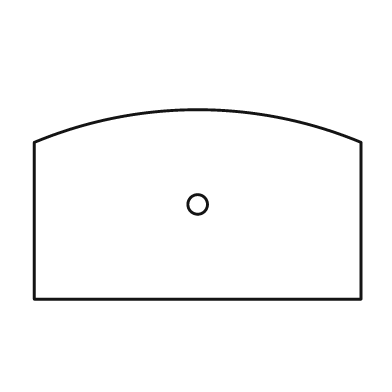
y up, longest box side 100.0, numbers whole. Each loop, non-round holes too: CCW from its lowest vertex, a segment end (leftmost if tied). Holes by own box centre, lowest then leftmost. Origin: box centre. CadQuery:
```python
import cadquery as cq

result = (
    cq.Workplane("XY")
    .moveTo(-50.0, -29.0)
    .lineTo(50.0, -29.0)
    .lineTo(50.0, 19.0)
    .threePointArc((0.0, 29.0), (-50.0, 19.0))
    .close()
    .moveTo(0.0, 0.0)
    .circle(3.0)
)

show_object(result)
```